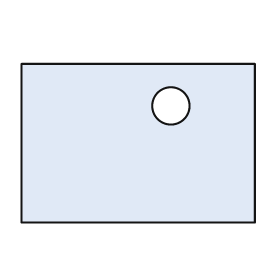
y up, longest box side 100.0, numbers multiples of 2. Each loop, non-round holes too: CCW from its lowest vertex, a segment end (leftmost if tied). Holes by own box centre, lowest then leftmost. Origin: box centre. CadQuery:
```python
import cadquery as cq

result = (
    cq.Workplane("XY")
    .moveTo(-50.0, -34.0)
    .lineTo(50.0, -34.0)
    .lineTo(50.0, 34.0)
    .lineTo(-50.0, 34.0)
    .close()
    .moveTo(14.0, 16.0)
    .circle(8.0)
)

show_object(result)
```